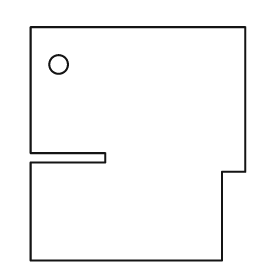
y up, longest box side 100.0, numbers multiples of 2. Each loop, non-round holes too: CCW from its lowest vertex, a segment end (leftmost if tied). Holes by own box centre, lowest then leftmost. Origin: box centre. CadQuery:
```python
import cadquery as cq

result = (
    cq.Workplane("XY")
    .moveTo(-46.0, -50.0)
    .lineTo(36.0, -50.0)
    .lineTo(36.0, -12.0)
    .lineTo(46.0, -12.0)
    .lineTo(46.0, 50.0)
    .lineTo(-46.0, 50.0)
    .lineTo(-46.0, -4.0)
    .lineTo(-14.0, -4.0)
    .lineTo(-14.0, -8.0)
    .lineTo(-46.0, -8.0)
    .close()
    .moveTo(-34.0, 34.0)
    .circle(4.0)
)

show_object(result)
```